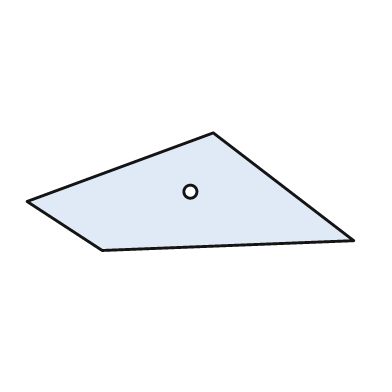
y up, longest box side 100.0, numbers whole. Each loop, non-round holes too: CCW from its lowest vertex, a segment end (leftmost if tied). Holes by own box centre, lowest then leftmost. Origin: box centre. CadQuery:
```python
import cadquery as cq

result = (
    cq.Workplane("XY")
    .moveTo(-27.0, -18.0)
    .lineTo(50.0, -15.0)
    .lineTo(7.0, 18.0)
    .lineTo(-50.0, -3.0)
    .close()
    .moveTo(0.0, 0.0)
    .circle(2.0)
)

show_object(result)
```